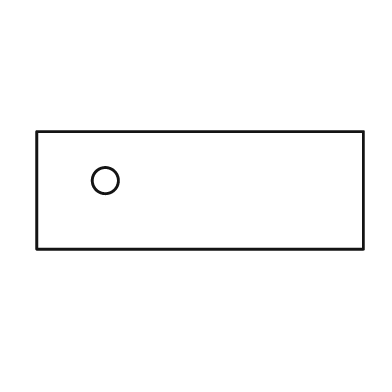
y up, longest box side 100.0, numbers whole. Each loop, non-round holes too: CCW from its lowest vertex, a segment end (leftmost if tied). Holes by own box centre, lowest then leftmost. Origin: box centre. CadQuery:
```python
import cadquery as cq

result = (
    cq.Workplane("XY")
    .moveTo(-50.0, -18.0)
    .lineTo(50.0, -18.0)
    .lineTo(50.0, 18.0)
    .lineTo(-50.0, 18.0)
    .close()
    .moveTo(-29.0, 3.0)
    .circle(4.0)
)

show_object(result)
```